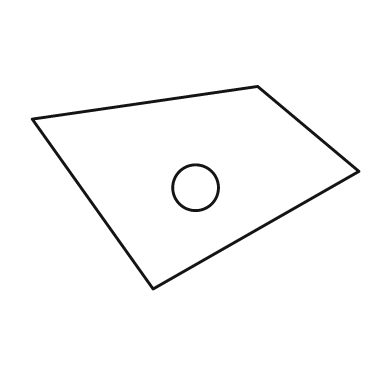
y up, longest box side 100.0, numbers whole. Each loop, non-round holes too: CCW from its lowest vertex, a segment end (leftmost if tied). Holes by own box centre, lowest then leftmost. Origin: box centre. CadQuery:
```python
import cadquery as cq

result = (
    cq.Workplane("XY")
    .moveTo(-13.0, -31.0)
    .lineTo(50.0, 5.0)
    .lineTo(19.0, 31.0)
    .lineTo(-50.0, 21.0)
    .close()
    .moveTo(0.0, 0.0)
    .circle(7.0)
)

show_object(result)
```